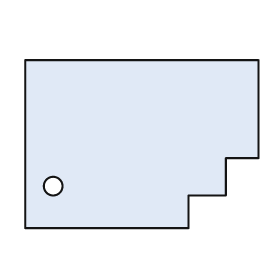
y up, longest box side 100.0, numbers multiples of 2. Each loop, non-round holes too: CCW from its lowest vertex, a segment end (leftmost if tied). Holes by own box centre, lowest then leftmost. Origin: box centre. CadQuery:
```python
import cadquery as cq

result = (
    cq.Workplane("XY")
    .moveTo(-50.0, -36.0)
    .lineTo(20.0, -36.0)
    .lineTo(20.0, -22.0)
    .lineTo(36.0, -22.0)
    .lineTo(36.0, -6.0)
    .lineTo(50.0, -6.0)
    .lineTo(50.0, 36.0)
    .lineTo(-50.0, 36.0)
    .close()
    .moveTo(-38.0, -18.0)
    .circle(4.0)
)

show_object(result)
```